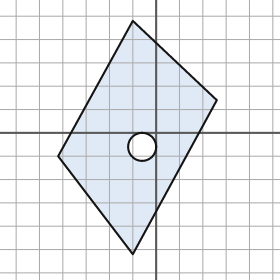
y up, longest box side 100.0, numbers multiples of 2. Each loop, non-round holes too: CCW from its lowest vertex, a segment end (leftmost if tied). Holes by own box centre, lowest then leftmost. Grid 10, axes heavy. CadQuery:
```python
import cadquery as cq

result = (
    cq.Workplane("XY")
    .moveTo(-10.0, -52.0)
    .lineTo(26.0, 14.0)
    .lineTo(-10.0, 48.0)
    .lineTo(-42.0, -10.0)
    .close()
    .moveTo(-6.0, -6.0)
    .circle(6.0)
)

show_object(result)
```